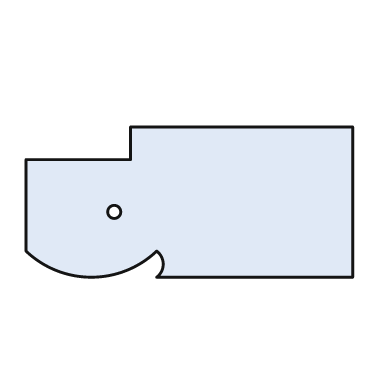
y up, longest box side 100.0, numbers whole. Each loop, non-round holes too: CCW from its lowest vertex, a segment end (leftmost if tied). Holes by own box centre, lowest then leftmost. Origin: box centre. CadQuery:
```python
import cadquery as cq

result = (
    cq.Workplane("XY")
    .moveTo(-10.0, -23.0)
    .lineTo(50.0, -23.0)
    .lineTo(50.0, 23.0)
    .lineTo(-18.0, 23.0)
    .lineTo(-18.0, 13.0)
    .lineTo(-50.0, 13.0)
    .lineTo(-50.0, -15.0)
    .threePointArc((-30.0, -23.0), (-10.0, -15.0))
    .threePointArc((-8.0, -19.0), (-10.0, -23.0))
    .close()
    .moveTo(-23.0, -3.0)
    .circle(2.0)
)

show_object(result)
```